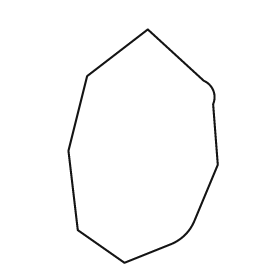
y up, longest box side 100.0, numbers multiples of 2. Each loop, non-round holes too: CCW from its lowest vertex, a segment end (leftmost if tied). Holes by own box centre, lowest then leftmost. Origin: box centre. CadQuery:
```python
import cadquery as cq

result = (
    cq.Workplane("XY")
    .moveTo(-8.0, -50.0)
    .lineTo(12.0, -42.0)
    .threePointArc((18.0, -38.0), (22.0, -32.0))
    .lineTo(32.0, -8.0)
    .lineTo(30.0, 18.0)
    .threePointArc((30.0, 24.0), (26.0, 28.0))
    .lineTo(2.0, 50.0)
    .lineTo(-24.0, 30.0)
    .lineTo(-32.0, -2.0)
    .lineTo(-28.0, -36.0)
    .close()
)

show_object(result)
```